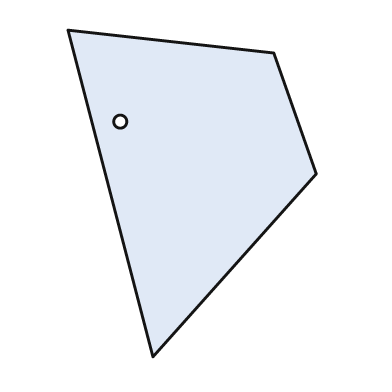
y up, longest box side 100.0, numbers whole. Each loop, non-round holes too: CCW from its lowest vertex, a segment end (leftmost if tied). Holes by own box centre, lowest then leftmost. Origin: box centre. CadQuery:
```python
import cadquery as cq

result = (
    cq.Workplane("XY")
    .moveTo(-12.0, -50.0)
    .lineTo(38.0, 6.0)
    .lineTo(25.0, 43.0)
    .lineTo(-38.0, 50.0)
    .close()
    .moveTo(-22.0, 22.0)
    .circle(2.0)
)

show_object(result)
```